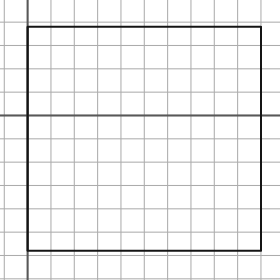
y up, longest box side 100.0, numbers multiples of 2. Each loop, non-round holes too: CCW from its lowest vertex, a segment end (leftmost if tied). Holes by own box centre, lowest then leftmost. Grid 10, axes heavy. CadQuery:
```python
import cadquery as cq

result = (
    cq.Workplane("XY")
    .moveTo(0.0, -58.0)
    .lineTo(100.0, -58.0)
    .lineTo(100.0, 38.0)
    .lineTo(0.0, 38.0)
    .close()
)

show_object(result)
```